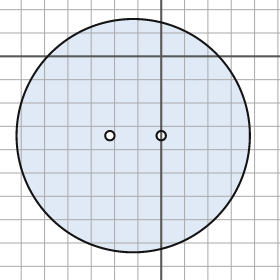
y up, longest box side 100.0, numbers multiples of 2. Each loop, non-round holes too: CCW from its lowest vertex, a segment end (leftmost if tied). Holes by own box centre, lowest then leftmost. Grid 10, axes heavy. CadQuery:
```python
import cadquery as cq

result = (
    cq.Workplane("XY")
    .moveTo(-12.0, -34.0)
    .circle(50.0)
    .moveTo(-22.0, -34.0)
    .circle(2.0)
    .moveTo(0.0, -34.0)
    .circle(2.0)
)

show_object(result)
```